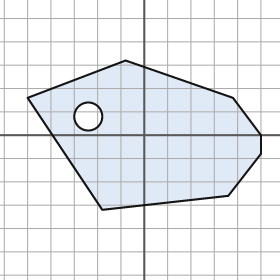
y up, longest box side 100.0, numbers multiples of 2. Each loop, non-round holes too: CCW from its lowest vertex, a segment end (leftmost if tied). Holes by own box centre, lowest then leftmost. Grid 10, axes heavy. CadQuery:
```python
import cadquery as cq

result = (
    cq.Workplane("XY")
    .moveTo(-18.0, -32.0)
    .lineTo(36.0, -26.0)
    .lineTo(50.0, -8.0)
    .lineTo(50.0, 0.0)
    .lineTo(38.0, 16.0)
    .lineTo(-8.0, 32.0)
    .lineTo(-50.0, 16.0)
    .close()
    .moveTo(-24.0, 8.0)
    .circle(6.0)
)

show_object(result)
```